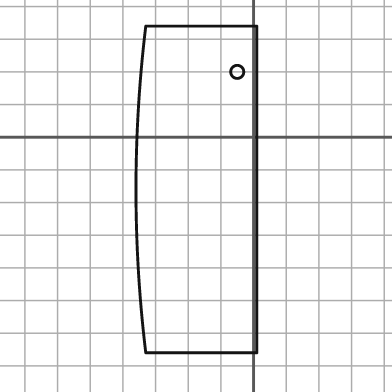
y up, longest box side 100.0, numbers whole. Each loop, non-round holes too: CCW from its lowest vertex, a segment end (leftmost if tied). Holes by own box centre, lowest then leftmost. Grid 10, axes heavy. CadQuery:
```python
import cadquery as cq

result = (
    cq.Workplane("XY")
    .moveTo(-33.0, -66.0)
    .lineTo(1.0, -66.0)
    .lineTo(1.0, 34.0)
    .lineTo(-33.0, 34.0)
    .threePointArc((-36.0, -16.0), (-33.0, -66.0))
    .close()
    .moveTo(-5.0, 20.0)
    .circle(2.0)
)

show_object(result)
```